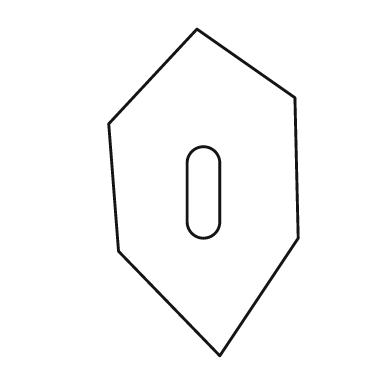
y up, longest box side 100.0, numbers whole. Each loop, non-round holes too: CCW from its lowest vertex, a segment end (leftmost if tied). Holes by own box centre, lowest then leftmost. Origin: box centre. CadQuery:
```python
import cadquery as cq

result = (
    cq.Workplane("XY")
    .moveTo(5.0, -50.0)
    .lineTo(29.0, -14.0)
    .lineTo(28.0, 29.0)
    .lineTo(-2.0, 50.0)
    .lineTo(-29.0, 21.0)
    .lineTo(-26.0, -18.0)
    .close()
    .moveTo(-5.0, -9.0)
    .threePointArc((0.0, -14.0), (5.0, -9.0))
    .lineTo(5.0, 9.0)
    .threePointArc((0.0, 14.0), (-5.0, 9.0))
    .close()
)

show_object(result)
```